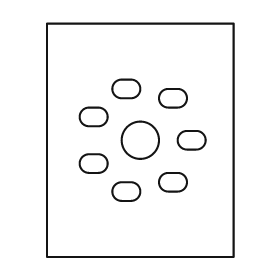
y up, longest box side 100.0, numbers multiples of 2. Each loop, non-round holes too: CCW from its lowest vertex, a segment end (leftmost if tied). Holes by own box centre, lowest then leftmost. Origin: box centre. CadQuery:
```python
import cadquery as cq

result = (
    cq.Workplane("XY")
    .moveTo(-40.0, -50.0)
    .lineTo(40.0, -50.0)
    .lineTo(40.0, 50.0)
    .lineTo(-40.0, 50.0)
    .close()
    .moveTo(-8.0, -26.0)
    .lineTo(-4.0, -26.0)
    .threePointArc((0.0, -22.0), (-4.0, -18.0))
    .lineTo(-8.0, -18.0)
    .threePointArc((-12.0, -22.0), (-8.0, -26.0))
    .close()
    .moveTo(12.0, -22.0)
    .lineTo(16.0, -22.0)
    .threePointArc((20.0, -18.0), (16.0, -14.0))
    .lineTo(12.0, -14.0)
    .threePointArc((8.0, -18.0), (12.0, -22.0))
    .close()
    .moveTo(-22.0, -14.0)
    .lineTo(-18.0, -14.0)
    .threePointArc((-14.0, -10.0), (-18.0, -6.0))
    .lineTo(-22.0, -6.0)
    .threePointArc((-26.0, -10.0), (-22.0, -14.0))
    .close()
    .moveTo(0.0, 0.0)
    .circle(8.0)
    .moveTo(20.0, -4.0)
    .lineTo(24.0, -4.0)
    .threePointArc((28.0, 0.0), (24.0, 4.0))
    .lineTo(20.0, 4.0)
    .threePointArc((16.0, 0.0), (20.0, -4.0))
    .close()
    .moveTo(-22.0, 6.0)
    .lineTo(-18.0, 6.0)
    .threePointArc((-14.0, 10.0), (-18.0, 14.0))
    .lineTo(-22.0, 14.0)
    .threePointArc((-26.0, 10.0), (-22.0, 6.0))
    .close()
    .moveTo(12.0, 14.0)
    .lineTo(16.0, 14.0)
    .threePointArc((20.0, 18.0), (16.0, 22.0))
    .lineTo(12.0, 22.0)
    .threePointArc((8.0, 18.0), (12.0, 14.0))
    .close()
    .moveTo(-8.0, 18.0)
    .lineTo(-4.0, 18.0)
    .threePointArc((0.0, 22.0), (-4.0, 26.0))
    .lineTo(-8.0, 26.0)
    .threePointArc((-12.0, 22.0), (-8.0, 18.0))
    .close()
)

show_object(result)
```